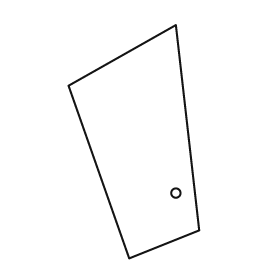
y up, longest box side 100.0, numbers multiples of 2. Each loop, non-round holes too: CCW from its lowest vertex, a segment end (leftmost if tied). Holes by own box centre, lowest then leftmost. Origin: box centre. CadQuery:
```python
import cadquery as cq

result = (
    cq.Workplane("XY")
    .moveTo(-2.0, -50.0)
    .lineTo(28.0, -38.0)
    .lineTo(18.0, 50.0)
    .lineTo(-28.0, 24.0)
    .close()
    .moveTo(18.0, -22.0)
    .circle(2.0)
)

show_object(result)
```